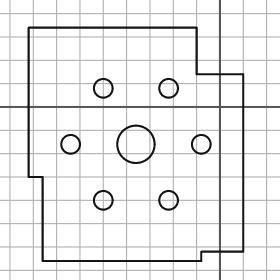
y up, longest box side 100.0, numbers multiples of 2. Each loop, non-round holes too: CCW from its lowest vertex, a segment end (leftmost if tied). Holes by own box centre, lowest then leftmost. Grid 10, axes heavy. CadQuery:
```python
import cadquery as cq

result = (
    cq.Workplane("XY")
    .moveTo(-76.0, -66.0)
    .lineTo(-8.0, -66.0)
    .lineTo(-8.0, -62.0)
    .lineTo(10.0, -62.0)
    .lineTo(10.0, 14.0)
    .lineTo(-10.0, 14.0)
    .lineTo(-10.0, 34.0)
    .lineTo(-82.0, 34.0)
    .lineTo(-82.0, -30.0)
    .lineTo(-76.0, -30.0)
    .close()
    .moveTo(-50.0, -40.0)
    .circle(4.0)
    .moveTo(-22.0, -40.0)
    .circle(4.0)
    .moveTo(-64.0, -16.0)
    .circle(4.0)
    .moveTo(-36.0, -16.0)
    .circle(8.0)
    .moveTo(-8.0, -16.0)
    .circle(4.0)
    .moveTo(-50.0, 8.0)
    .circle(4.0)
    .moveTo(-22.0, 8.0)
    .circle(4.0)
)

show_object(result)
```